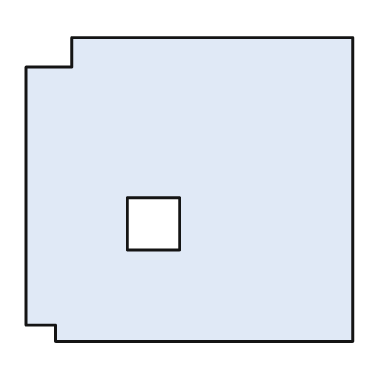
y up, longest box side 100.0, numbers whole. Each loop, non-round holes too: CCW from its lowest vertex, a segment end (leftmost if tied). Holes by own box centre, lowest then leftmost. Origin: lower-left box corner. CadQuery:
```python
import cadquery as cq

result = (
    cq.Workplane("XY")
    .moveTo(9.0, 0.0)
    .lineTo(100.0, 0.0)
    .lineTo(100.0, 93.0)
    .lineTo(14.0, 93.0)
    .lineTo(14.0, 84.0)
    .lineTo(0.0, 84.0)
    .lineTo(0.0, 5.0)
    .lineTo(9.0, 5.0)
    .close()
    .moveTo(31.0, 28.0)
    .lineTo(47.0, 28.0)
    .lineTo(47.0, 44.0)
    .lineTo(31.0, 44.0)
    .close()
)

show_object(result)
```